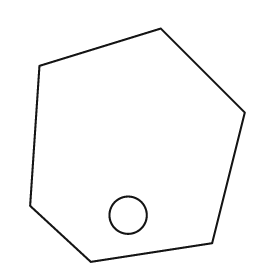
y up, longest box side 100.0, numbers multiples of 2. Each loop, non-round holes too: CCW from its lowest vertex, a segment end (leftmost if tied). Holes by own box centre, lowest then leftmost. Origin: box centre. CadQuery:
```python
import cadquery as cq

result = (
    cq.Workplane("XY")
    .moveTo(-20.0, -50.0)
    .lineTo(32.0, -42.0)
    .lineTo(46.0, 14.0)
    .lineTo(10.0, 50.0)
    .lineTo(-42.0, 34.0)
    .lineTo(-46.0, -26.0)
    .close()
    .moveTo(-4.0, -30.0)
    .circle(8.0)
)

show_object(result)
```